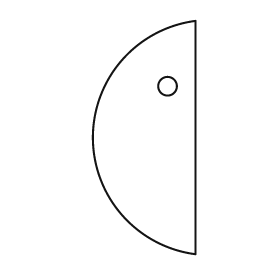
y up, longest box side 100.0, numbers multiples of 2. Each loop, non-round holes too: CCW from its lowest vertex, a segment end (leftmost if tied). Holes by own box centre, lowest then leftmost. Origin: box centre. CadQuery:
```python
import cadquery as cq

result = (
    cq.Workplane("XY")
    .moveTo(22.0, -50.0)
    .lineTo(22.0, 50.0)
    .threePointArc((-22.0, 0.0), (22.0, -50.0))
    .close()
    .moveTo(10.0, 22.0)
    .circle(4.0)
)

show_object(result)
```